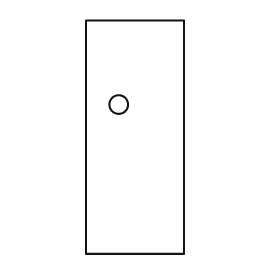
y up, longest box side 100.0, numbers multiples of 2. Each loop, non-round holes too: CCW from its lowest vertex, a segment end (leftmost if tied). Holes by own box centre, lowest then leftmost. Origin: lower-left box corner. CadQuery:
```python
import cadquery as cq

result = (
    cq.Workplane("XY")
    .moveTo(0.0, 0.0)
    .lineTo(42.0, 0.0)
    .lineTo(42.0, 100.0)
    .lineTo(0.0, 100.0)
    .close()
    .moveTo(14.0, 64.0)
    .circle(4.0)
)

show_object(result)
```